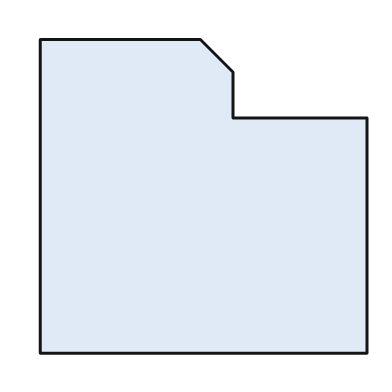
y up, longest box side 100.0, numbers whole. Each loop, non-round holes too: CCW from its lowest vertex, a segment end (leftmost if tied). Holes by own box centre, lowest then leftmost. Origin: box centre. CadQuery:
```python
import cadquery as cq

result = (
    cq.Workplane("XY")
    .moveTo(-50.0, -48.0)
    .lineTo(50.0, -48.0)
    .lineTo(50.0, 24.0)
    .lineTo(9.0, 24.0)
    .lineTo(9.0, 38.0)
    .lineTo(-1.0, 48.0)
    .lineTo(-50.0, 48.0)
    .close()
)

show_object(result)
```